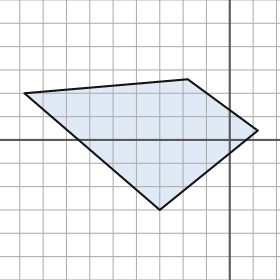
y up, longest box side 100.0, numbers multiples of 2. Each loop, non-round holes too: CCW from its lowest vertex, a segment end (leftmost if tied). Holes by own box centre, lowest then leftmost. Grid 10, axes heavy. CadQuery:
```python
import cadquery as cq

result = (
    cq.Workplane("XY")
    .moveTo(-30.0, -30.0)
    .lineTo(12.0, 4.0)
    .lineTo(-18.0, 26.0)
    .lineTo(-88.0, 20.0)
    .close()
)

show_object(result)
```